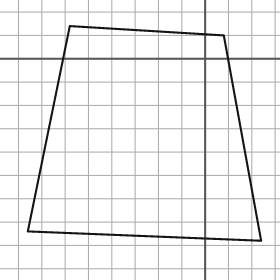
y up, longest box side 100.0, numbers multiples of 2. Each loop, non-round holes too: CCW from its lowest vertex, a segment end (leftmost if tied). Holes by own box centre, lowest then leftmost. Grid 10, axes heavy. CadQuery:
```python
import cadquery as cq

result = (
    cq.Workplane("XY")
    .moveTo(24.0, -78.0)
    .lineTo(8.0, 10.0)
    .lineTo(-58.0, 14.0)
    .lineTo(-76.0, -74.0)
    .close()
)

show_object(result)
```